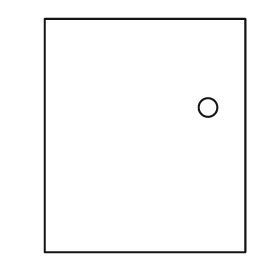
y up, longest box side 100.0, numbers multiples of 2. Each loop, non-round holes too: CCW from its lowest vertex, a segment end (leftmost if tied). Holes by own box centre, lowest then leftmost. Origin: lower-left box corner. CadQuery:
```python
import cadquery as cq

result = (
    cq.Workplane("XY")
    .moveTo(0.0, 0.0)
    .lineTo(86.0, 0.0)
    .lineTo(86.0, 100.0)
    .lineTo(0.0, 100.0)
    .close()
    .moveTo(70.0, 62.0)
    .circle(4.0)
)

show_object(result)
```